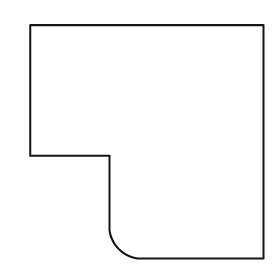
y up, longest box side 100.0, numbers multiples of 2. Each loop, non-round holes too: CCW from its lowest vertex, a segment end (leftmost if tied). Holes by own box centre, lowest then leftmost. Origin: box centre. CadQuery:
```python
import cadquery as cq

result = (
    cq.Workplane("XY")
    .moveTo(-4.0, -50.0)
    .lineTo(50.0, -50.0)
    .lineTo(50.0, 50.0)
    .lineTo(-50.0, 50.0)
    .lineTo(-50.0, -6.0)
    .lineTo(-16.0, -6.0)
    .lineTo(-16.0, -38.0)
    .threePointArc((-12.0, -46.0), (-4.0, -50.0))
    .close()
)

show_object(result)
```